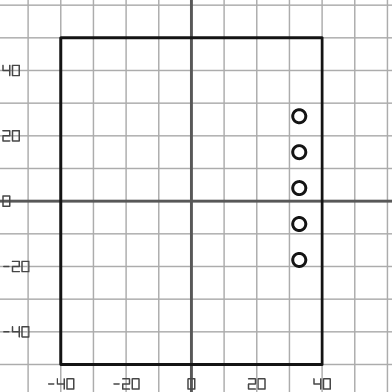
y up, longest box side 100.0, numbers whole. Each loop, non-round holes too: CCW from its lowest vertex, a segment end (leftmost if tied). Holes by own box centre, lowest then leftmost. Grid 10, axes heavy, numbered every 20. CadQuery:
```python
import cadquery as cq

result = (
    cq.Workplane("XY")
    .moveTo(-40.0, -50.0)
    .lineTo(40.0, -50.0)
    .lineTo(40.0, 50.0)
    .lineTo(-40.0, 50.0)
    .close()
    .moveTo(33.0, -18.0)
    .circle(2.0)
    .moveTo(33.0, -7.0)
    .circle(2.0)
    .moveTo(33.0, 4.0)
    .circle(2.0)
    .moveTo(33.0, 15.0)
    .circle(2.0)
    .moveTo(33.0, 26.0)
    .circle(2.0)
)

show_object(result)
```